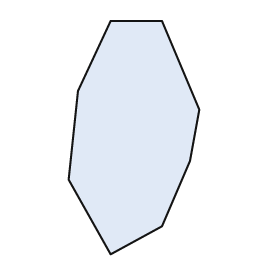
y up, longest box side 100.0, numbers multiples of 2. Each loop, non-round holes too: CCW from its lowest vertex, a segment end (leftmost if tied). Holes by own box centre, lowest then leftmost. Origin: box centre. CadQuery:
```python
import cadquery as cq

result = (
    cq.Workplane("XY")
    .moveTo(-10.0, -50.0)
    .lineTo(12.0, -38.0)
    .lineTo(24.0, -10.0)
    .lineTo(28.0, 12.0)
    .lineTo(12.0, 50.0)
    .lineTo(-10.0, 50.0)
    .lineTo(-24.0, 20.0)
    .lineTo(-28.0, -18.0)
    .close()
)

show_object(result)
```